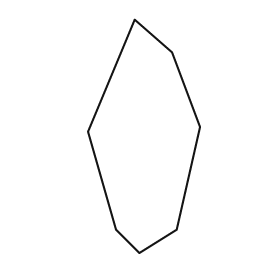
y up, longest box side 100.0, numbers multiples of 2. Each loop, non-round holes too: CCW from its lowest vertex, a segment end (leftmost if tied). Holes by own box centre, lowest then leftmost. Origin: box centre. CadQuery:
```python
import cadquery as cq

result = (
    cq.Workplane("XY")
    .moveTo(-2.0, -50.0)
    .lineTo(14.0, -40.0)
    .lineTo(24.0, 4.0)
    .lineTo(12.0, 36.0)
    .lineTo(-4.0, 50.0)
    .lineTo(-24.0, 2.0)
    .lineTo(-12.0, -40.0)
    .close()
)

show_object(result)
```